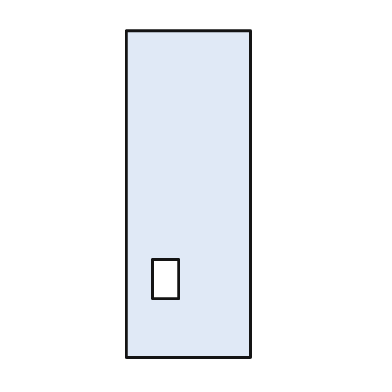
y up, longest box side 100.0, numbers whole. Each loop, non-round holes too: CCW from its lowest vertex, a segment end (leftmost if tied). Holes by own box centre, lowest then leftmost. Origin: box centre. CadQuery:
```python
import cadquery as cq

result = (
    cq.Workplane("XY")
    .moveTo(-19.0, -50.0)
    .lineTo(19.0, -50.0)
    .lineTo(19.0, 50.0)
    .lineTo(-19.0, 50.0)
    .close()
    .moveTo(-11.0, -32.0)
    .lineTo(-3.0, -32.0)
    .lineTo(-3.0, -20.0)
    .lineTo(-11.0, -20.0)
    .close()
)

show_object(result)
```